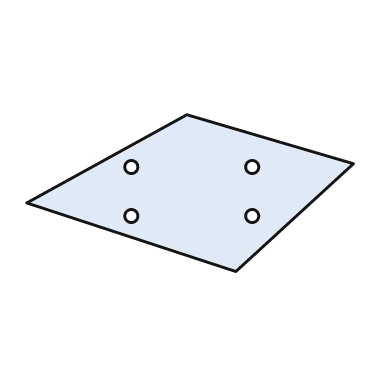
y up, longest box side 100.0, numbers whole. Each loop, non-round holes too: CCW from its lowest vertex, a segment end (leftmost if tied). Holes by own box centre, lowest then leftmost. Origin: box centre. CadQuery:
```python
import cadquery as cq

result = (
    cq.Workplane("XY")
    .moveTo(14.0, -24.0)
    .lineTo(50.0, 9.0)
    .lineTo(-1.0, 24.0)
    .lineTo(-50.0, -3.0)
    .close()
    .moveTo(-18.0, -7.0)
    .circle(2.0)
    .moveTo(19.0, -7.0)
    .circle(2.0)
    .moveTo(-18.0, 8.0)
    .circle(2.0)
    .moveTo(19.0, 8.0)
    .circle(2.0)
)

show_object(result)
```